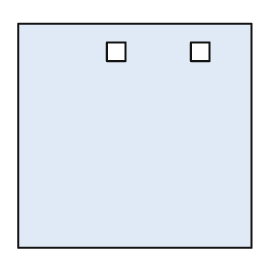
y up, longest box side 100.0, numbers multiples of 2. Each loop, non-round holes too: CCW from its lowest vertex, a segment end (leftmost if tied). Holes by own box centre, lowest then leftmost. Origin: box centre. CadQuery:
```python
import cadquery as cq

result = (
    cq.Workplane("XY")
    .moveTo(-50.0, -48.0)
    .lineTo(50.0, -48.0)
    .lineTo(50.0, 48.0)
    .lineTo(-50.0, 48.0)
    .close()
    .moveTo(-12.0, 32.0)
    .lineTo(-4.0, 32.0)
    .lineTo(-4.0, 40.0)
    .lineTo(-12.0, 40.0)
    .close()
    .moveTo(24.0, 32.0)
    .lineTo(32.0, 32.0)
    .lineTo(32.0, 40.0)
    .lineTo(24.0, 40.0)
    .close()
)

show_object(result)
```